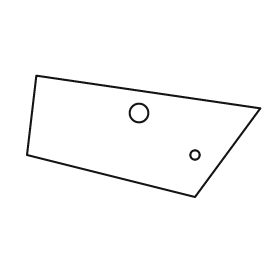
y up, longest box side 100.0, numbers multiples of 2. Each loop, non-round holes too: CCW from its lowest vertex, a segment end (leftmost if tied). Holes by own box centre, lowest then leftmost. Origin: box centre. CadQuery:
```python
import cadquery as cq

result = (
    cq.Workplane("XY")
    .moveTo(22.0, -26.0)
    .lineTo(50.0, 12.0)
    .lineTo(-46.0, 26.0)
    .lineTo(-50.0, -8.0)
    .close()
    .moveTo(22.0, -8.0)
    .circle(2.0)
    .moveTo(-2.0, 10.0)
    .circle(4.0)
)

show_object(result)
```